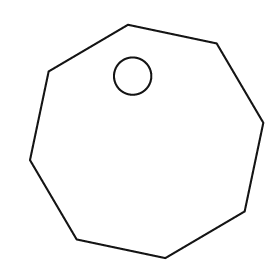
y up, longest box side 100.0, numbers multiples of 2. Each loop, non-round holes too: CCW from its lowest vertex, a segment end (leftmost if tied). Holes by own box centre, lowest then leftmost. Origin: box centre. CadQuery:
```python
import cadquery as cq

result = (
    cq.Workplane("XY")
    .moveTo(8.0, -50.0)
    .lineTo(42.0, -30.0)
    .lineTo(50.0, 8.0)
    .lineTo(30.0, 42.0)
    .lineTo(-8.0, 50.0)
    .lineTo(-42.0, 30.0)
    .lineTo(-50.0, -8.0)
    .lineTo(-30.0, -42.0)
    .close()
    .moveTo(-6.0, 28.0)
    .circle(8.0)
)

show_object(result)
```